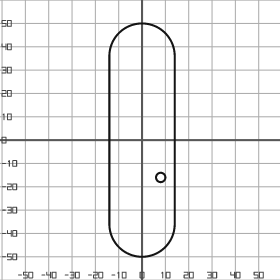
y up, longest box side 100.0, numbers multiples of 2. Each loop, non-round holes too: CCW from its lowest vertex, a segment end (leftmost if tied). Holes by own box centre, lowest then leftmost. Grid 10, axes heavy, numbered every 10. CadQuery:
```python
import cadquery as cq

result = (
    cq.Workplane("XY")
    .moveTo(-14.0, -36.0)
    .threePointArc((0.0, -50.0), (14.0, -36.0))
    .lineTo(14.0, 36.0)
    .threePointArc((0.0, 50.0), (-14.0, 36.0))
    .close()
    .moveTo(8.0, -16.0)
    .circle(2.0)
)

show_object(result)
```